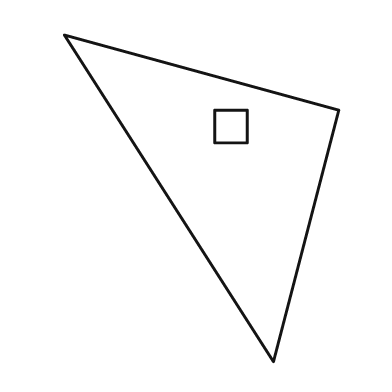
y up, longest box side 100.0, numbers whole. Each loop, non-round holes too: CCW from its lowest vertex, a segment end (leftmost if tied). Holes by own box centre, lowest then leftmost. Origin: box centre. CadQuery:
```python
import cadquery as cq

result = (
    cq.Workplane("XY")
    .moveTo(22.0, -50.0)
    .lineTo(42.0, 27.0)
    .lineTo(-42.0, 50.0)
    .close()
    .moveTo(4.0, 17.0)
    .lineTo(14.0, 17.0)
    .lineTo(14.0, 27.0)
    .lineTo(4.0, 27.0)
    .close()
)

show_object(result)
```